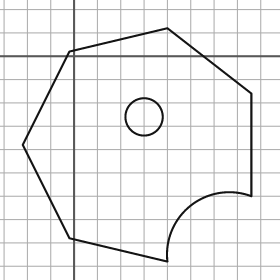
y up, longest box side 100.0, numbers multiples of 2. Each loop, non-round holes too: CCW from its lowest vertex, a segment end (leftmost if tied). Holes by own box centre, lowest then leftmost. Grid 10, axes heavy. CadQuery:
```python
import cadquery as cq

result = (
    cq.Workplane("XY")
    .moveTo(40.0, -88.0)
    .threePointArc((50.0, -64.0), (76.0, -60.0))
    .lineTo(76.0, -16.0)
    .lineTo(40.0, 12.0)
    .lineTo(-2.0, 2.0)
    .lineTo(-22.0, -38.0)
    .lineTo(-2.0, -78.0)
    .close()
    .moveTo(30.0, -26.0)
    .circle(8.0)
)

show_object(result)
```